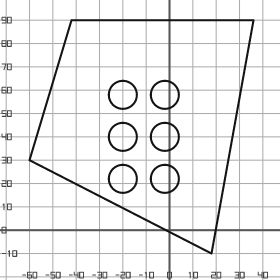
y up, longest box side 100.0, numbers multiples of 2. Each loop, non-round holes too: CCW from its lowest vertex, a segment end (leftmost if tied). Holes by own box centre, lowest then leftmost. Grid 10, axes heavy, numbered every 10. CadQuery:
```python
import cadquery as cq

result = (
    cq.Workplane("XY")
    .moveTo(18.0, -10.0)
    .lineTo(36.0, 90.0)
    .lineTo(-42.0, 90.0)
    .lineTo(-60.0, 30.0)
    .close()
    .moveTo(-20.0, 22.0)
    .circle(6.0)
    .moveTo(-2.0, 22.0)
    .circle(6.0)
    .moveTo(-20.0, 40.0)
    .circle(6.0)
    .moveTo(-2.0, 40.0)
    .circle(6.0)
    .moveTo(-20.0, 58.0)
    .circle(6.0)
    .moveTo(-2.0, 58.0)
    .circle(6.0)
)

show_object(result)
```